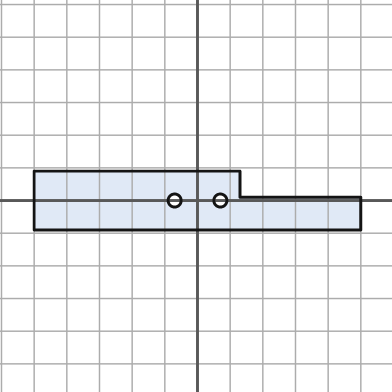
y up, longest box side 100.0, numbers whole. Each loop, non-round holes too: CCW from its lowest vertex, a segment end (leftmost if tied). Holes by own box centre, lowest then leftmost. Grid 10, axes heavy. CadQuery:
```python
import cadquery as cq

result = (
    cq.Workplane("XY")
    .moveTo(-50.0, -9.0)
    .lineTo(50.0, -9.0)
    .lineTo(50.0, 1.0)
    .lineTo(13.0, 1.0)
    .lineTo(13.0, 9.0)
    .lineTo(-50.0, 9.0)
    .close()
    .moveTo(-7.0, 0.0)
    .circle(2.0)
    .moveTo(7.0, 0.0)
    .circle(2.0)
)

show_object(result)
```